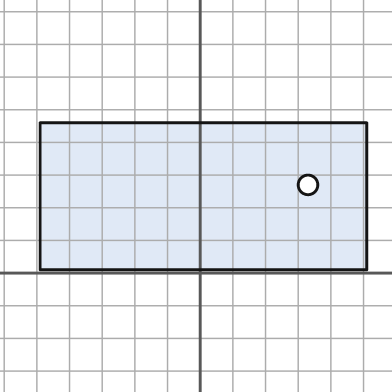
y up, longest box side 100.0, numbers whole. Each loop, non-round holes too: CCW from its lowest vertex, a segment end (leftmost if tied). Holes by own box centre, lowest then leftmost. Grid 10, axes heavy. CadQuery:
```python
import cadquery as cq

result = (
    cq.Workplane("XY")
    .moveTo(-49.0, 1.0)
    .lineTo(51.0, 1.0)
    .lineTo(51.0, 46.0)
    .lineTo(-49.0, 46.0)
    .close()
    .moveTo(33.0, 27.0)
    .circle(3.0)
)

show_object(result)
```